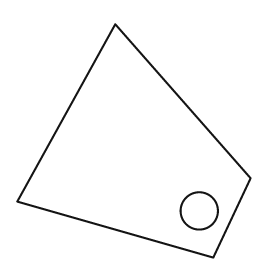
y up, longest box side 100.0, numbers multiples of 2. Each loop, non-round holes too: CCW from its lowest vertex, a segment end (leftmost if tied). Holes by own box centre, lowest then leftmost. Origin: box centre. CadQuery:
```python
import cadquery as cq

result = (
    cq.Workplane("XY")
    .moveTo(34.0, -50.0)
    .lineTo(50.0, -16.0)
    .lineTo(-8.0, 50.0)
    .lineTo(-50.0, -26.0)
    .close()
    .moveTo(28.0, -30.0)
    .circle(8.0)
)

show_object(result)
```